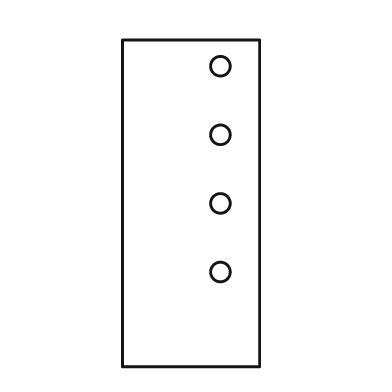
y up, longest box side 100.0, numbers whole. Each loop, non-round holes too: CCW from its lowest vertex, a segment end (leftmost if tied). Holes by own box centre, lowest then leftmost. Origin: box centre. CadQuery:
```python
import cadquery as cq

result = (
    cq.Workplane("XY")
    .moveTo(-21.0, -50.0)
    .lineTo(21.0, -50.0)
    .lineTo(21.0, 50.0)
    .lineTo(-21.0, 50.0)
    .close()
    .moveTo(9.0, -21.0)
    .circle(3.0)
    .moveTo(9.0, 0.0)
    .circle(3.0)
    .moveTo(9.0, 21.0)
    .circle(3.0)
    .moveTo(9.0, 42.0)
    .circle(3.0)
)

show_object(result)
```